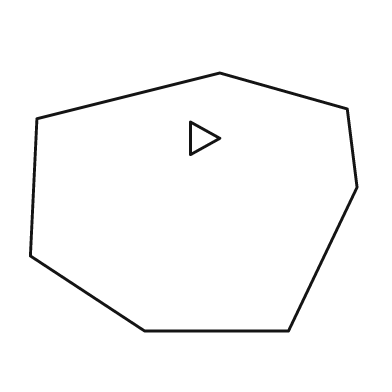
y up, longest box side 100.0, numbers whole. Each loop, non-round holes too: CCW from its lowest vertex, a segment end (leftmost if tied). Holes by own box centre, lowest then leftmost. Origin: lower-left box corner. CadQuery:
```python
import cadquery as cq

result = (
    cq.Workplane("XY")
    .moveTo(35.0, 0.0)
    .lineTo(79.0, 0.0)
    .lineTo(100.0, 44.0)
    .lineTo(97.0, 68.0)
    .lineTo(58.0, 79.0)
    .lineTo(2.0, 65.0)
    .lineTo(0.0, 23.0)
    .close()
    .moveTo(49.0, 54.0)
    .lineTo(58.0, 59.0)
    .lineTo(49.0, 64.0)
    .close()
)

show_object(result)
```